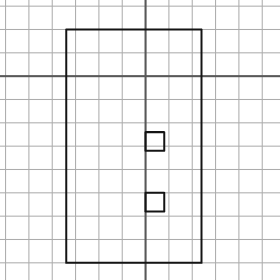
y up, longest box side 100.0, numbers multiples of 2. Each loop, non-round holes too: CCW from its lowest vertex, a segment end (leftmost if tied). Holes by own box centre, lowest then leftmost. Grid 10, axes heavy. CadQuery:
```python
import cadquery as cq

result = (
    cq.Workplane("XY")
    .moveTo(-34.0, -80.0)
    .lineTo(24.0, -80.0)
    .lineTo(24.0, 20.0)
    .lineTo(-34.0, 20.0)
    .close()
    .moveTo(0.0, -58.0)
    .lineTo(8.0, -58.0)
    .lineTo(8.0, -50.0)
    .lineTo(0.0, -50.0)
    .close()
    .moveTo(0.0, -32.0)
    .lineTo(8.0, -32.0)
    .lineTo(8.0, -24.0)
    .lineTo(0.0, -24.0)
    .close()
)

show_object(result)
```